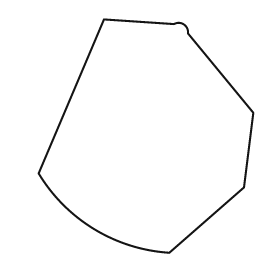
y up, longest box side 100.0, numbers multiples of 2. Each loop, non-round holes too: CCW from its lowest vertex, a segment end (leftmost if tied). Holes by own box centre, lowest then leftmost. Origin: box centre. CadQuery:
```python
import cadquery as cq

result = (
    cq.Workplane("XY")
    .moveTo(10.0, -50.0)
    .lineTo(42.0, -22.0)
    .lineTo(46.0, 10.0)
    .lineTo(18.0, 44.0)
    .threePointArc((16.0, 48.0), (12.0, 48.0))
    .lineTo(-18.0, 50.0)
    .lineTo(-46.0, -16.0)
    .threePointArc((-22.0, -40.0), (10.0, -50.0))
    .close()
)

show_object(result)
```